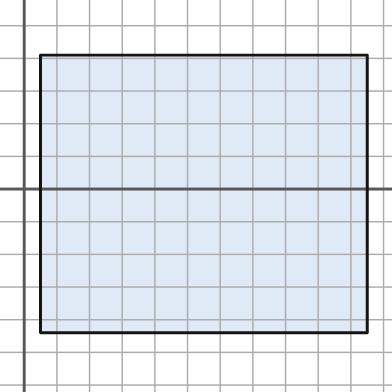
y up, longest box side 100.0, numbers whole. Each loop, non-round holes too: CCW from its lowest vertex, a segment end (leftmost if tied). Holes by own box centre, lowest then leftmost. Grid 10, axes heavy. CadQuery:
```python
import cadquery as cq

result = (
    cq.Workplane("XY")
    .moveTo(5.0, -44.0)
    .lineTo(105.0, -44.0)
    .lineTo(105.0, 41.0)
    .lineTo(5.0, 41.0)
    .close()
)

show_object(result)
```